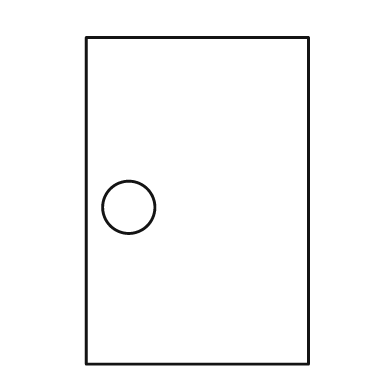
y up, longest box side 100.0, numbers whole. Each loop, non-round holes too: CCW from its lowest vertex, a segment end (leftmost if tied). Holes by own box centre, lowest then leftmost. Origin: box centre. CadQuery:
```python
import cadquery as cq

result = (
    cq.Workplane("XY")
    .moveTo(-34.0, -50.0)
    .lineTo(34.0, -50.0)
    .lineTo(34.0, 50.0)
    .lineTo(-34.0, 50.0)
    .close()
    .moveTo(-21.0, -2.0)
    .circle(8.0)
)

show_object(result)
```